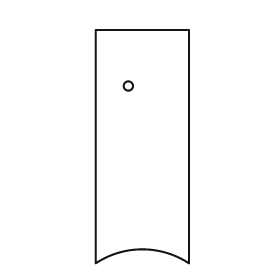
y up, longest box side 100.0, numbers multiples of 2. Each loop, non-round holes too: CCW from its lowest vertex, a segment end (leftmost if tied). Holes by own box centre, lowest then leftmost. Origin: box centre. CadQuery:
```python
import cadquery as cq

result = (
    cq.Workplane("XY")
    .moveTo(-20.0, -50.0)
    .threePointArc((0.0, -44.0), (20.0, -50.0))
    .lineTo(20.0, 50.0)
    .lineTo(-20.0, 50.0)
    .close()
    .moveTo(-6.0, 26.0)
    .circle(2.0)
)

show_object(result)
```